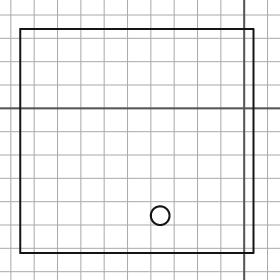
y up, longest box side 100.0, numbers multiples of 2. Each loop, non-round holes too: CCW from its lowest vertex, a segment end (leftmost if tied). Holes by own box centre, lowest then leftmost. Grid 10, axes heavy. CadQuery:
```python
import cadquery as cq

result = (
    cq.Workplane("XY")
    .moveTo(-96.0, -62.0)
    .lineTo(4.0, -62.0)
    .lineTo(4.0, 34.0)
    .lineTo(-96.0, 34.0)
    .close()
    .moveTo(-36.0, -46.0)
    .circle(4.0)
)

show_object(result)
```